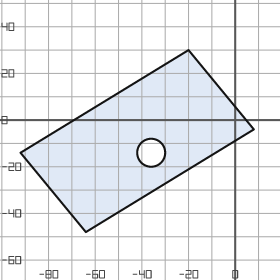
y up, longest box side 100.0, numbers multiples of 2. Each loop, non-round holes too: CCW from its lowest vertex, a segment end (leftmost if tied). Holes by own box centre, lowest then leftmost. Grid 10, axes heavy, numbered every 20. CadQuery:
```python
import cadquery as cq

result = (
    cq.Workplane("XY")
    .moveTo(-64.0, -48.0)
    .lineTo(8.0, -4.0)
    .lineTo(-20.0, 30.0)
    .lineTo(-92.0, -14.0)
    .close()
    .moveTo(-36.0, -14.0)
    .circle(6.0)
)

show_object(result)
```